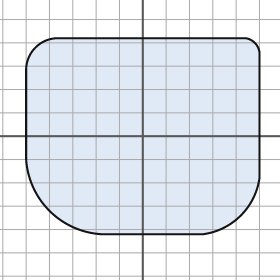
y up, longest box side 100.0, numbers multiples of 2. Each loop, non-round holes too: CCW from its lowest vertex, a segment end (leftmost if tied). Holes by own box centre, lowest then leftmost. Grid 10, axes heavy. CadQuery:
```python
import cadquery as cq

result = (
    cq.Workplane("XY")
    .moveTo(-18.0, -42.0)
    .lineTo(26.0, -42.0)
    .threePointArc((42.0, -34.0), (50.0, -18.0))
    .lineTo(50.0, 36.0)
    .threePointArc((48.0, 40.0), (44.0, 42.0))
    .lineTo(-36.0, 42.0)
    .threePointArc((-46.0, 38.0), (-50.0, 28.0))
    .lineTo(-50.0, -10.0)
    .threePointArc((-40.0, -32.0), (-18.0, -42.0))
    .close()
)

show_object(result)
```